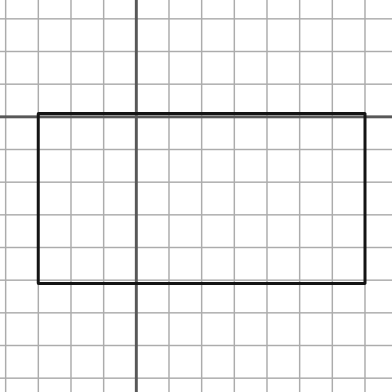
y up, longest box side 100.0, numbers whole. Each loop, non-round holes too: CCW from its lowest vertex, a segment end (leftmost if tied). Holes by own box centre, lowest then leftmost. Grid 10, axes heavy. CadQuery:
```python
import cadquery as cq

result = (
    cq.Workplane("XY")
    .moveTo(-30.0, -51.0)
    .lineTo(70.0, -51.0)
    .lineTo(70.0, 1.0)
    .lineTo(-30.0, 1.0)
    .close()
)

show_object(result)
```